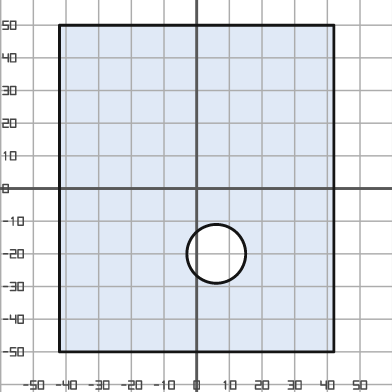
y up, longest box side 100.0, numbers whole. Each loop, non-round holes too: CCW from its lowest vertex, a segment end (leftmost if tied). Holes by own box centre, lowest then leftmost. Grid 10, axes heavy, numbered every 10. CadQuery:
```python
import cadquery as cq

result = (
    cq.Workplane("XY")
    .moveTo(-42.0, -50.0)
    .lineTo(42.0, -50.0)
    .lineTo(42.0, 50.0)
    .lineTo(-42.0, 50.0)
    .close()
    .moveTo(6.0, -20.0)
    .circle(9.0)
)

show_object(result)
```